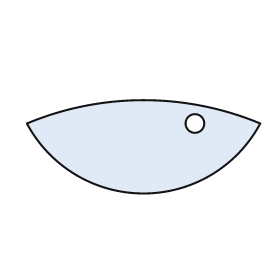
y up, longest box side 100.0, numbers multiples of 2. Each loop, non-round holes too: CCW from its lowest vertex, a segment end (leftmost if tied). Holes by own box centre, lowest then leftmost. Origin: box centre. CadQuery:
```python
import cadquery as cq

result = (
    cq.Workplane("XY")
    .moveTo(-50.0, 10.0)
    .threePointArc((0.0, -20.0), (50.0, 10.0))
    .threePointArc((0.0, 20.0), (-50.0, 10.0))
    .close()
    .moveTo(22.0, 10.0)
    .circle(4.0)
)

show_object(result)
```